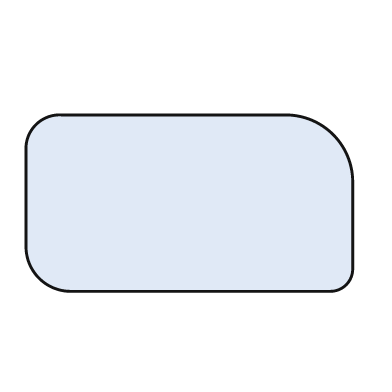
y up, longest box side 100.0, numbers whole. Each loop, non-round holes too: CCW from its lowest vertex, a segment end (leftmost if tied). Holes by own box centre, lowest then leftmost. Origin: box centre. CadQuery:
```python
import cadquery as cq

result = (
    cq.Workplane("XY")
    .moveTo(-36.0, -27.0)
    .lineTo(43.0, -27.0)
    .threePointArc((48.0, -25.0), (50.0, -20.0))
    .lineTo(50.0, 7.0)
    .threePointArc((44.0, 21.0), (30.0, 27.0))
    .lineTo(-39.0, 27.0)
    .threePointArc((-47.0, 24.0), (-50.0, 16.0))
    .lineTo(-50.0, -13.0)
    .threePointArc((-46.0, -23.0), (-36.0, -27.0))
    .close()
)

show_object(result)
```